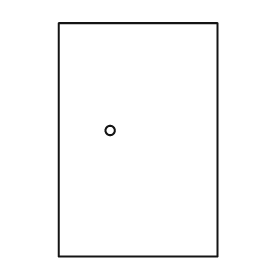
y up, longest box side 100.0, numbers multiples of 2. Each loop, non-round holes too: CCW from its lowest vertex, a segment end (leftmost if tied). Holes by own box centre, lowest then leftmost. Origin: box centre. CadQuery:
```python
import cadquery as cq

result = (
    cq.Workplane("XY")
    .moveTo(-34.0, -50.0)
    .lineTo(34.0, -50.0)
    .lineTo(34.0, 50.0)
    .lineTo(-34.0, 50.0)
    .close()
    .moveTo(-12.0, 4.0)
    .circle(2.0)
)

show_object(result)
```